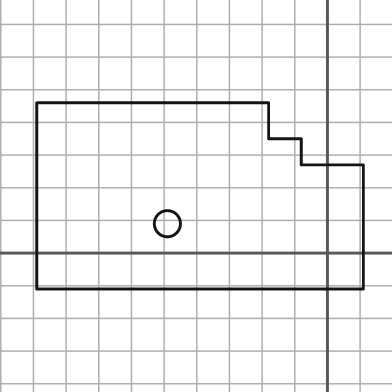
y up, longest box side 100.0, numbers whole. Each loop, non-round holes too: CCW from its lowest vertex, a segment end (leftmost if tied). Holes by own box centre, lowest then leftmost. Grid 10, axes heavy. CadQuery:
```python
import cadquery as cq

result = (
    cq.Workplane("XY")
    .moveTo(-89.0, -11.0)
    .lineTo(11.0, -11.0)
    .lineTo(11.0, 27.0)
    .lineTo(-8.0, 27.0)
    .lineTo(-8.0, 35.0)
    .lineTo(-18.0, 35.0)
    .lineTo(-18.0, 46.0)
    .lineTo(-89.0, 46.0)
    .close()
    .moveTo(-49.0, 9.0)
    .circle(4.0)
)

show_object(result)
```